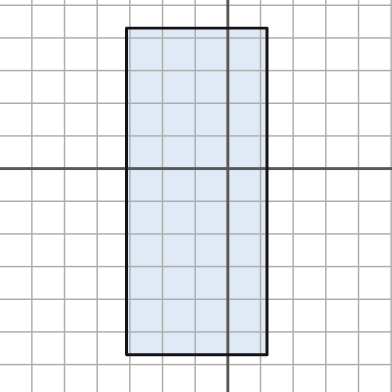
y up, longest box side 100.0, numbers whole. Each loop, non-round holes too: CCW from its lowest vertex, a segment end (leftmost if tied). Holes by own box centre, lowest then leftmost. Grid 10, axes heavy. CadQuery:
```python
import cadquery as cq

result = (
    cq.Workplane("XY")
    .moveTo(-31.0, -57.0)
    .lineTo(12.0, -57.0)
    .lineTo(12.0, 43.0)
    .lineTo(-31.0, 43.0)
    .close()
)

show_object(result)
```